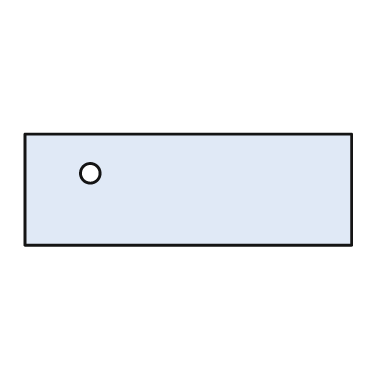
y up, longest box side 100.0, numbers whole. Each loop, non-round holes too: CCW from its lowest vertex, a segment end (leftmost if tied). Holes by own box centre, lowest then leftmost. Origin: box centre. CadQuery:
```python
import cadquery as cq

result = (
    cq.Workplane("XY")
    .moveTo(-50.0, -17.0)
    .lineTo(50.0, -17.0)
    .lineTo(50.0, 17.0)
    .lineTo(-50.0, 17.0)
    .close()
    .moveTo(-30.0, 5.0)
    .circle(3.0)
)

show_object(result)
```